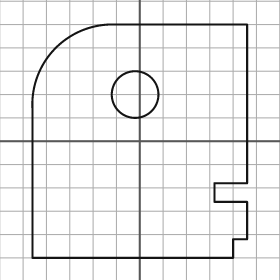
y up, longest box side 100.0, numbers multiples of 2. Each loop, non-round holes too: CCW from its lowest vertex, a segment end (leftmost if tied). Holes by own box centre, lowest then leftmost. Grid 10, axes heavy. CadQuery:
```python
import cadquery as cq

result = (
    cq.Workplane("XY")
    .moveTo(-46.0, -50.0)
    .lineTo(40.0, -50.0)
    .lineTo(40.0, -42.0)
    .lineTo(46.0, -42.0)
    .lineTo(46.0, -26.0)
    .lineTo(32.0, -26.0)
    .lineTo(32.0, -18.0)
    .lineTo(46.0, -18.0)
    .lineTo(46.0, 50.0)
    .lineTo(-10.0, 50.0)
    .threePointArc((-36.0, 40.0), (-46.0, 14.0))
    .close()
    .moveTo(-2.0, 20.0)
    .circle(10.0)
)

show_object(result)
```